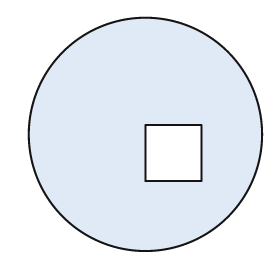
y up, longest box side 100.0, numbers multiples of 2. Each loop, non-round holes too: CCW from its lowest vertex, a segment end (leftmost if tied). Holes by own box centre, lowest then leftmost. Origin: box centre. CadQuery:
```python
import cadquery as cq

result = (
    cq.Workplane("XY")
    .moveTo(0.0, 0.0)
    .circle(50.0)
    .moveTo(0.0, -20.0)
    .lineTo(24.0, -20.0)
    .lineTo(24.0, 4.0)
    .lineTo(0.0, 4.0)
    .close()
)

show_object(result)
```